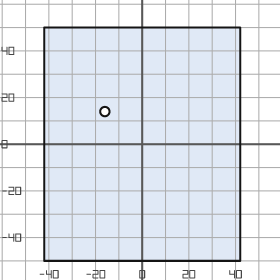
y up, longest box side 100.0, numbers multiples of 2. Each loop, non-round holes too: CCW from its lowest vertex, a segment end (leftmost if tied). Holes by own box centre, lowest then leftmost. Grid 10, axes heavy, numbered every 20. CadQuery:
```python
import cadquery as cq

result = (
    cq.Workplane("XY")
    .moveTo(-42.0, -50.0)
    .lineTo(42.0, -50.0)
    .lineTo(42.0, 50.0)
    .lineTo(-42.0, 50.0)
    .close()
    .moveTo(-16.0, 14.0)
    .circle(2.0)
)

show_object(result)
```